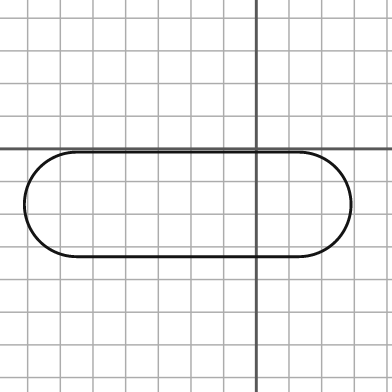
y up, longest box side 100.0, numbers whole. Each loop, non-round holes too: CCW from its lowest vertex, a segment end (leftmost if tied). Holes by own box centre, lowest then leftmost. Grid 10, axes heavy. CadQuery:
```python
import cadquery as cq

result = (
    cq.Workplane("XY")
    .moveTo(-55.0, -33.0)
    .lineTo(13.0, -33.0)
    .threePointArc((29.0, -17.0), (13.0, -1.0))
    .lineTo(-55.0, -1.0)
    .threePointArc((-71.0, -17.0), (-55.0, -33.0))
    .close()
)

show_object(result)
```